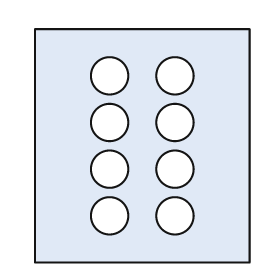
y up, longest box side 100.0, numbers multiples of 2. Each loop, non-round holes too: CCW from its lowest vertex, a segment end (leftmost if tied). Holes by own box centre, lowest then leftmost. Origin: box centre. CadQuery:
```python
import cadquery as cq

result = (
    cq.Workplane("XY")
    .moveTo(-46.0, -50.0)
    .lineTo(46.0, -50.0)
    .lineTo(46.0, 50.0)
    .lineTo(-46.0, 50.0)
    .close()
    .moveTo(-14.0, -30.0)
    .circle(8.0)
    .moveTo(14.0, -30.0)
    .circle(8.0)
    .moveTo(-14.0, -10.0)
    .circle(8.0)
    .moveTo(14.0, -10.0)
    .circle(8.0)
    .moveTo(-14.0, 10.0)
    .circle(8.0)
    .moveTo(14.0, 10.0)
    .circle(8.0)
    .moveTo(-14.0, 30.0)
    .circle(8.0)
    .moveTo(14.0, 30.0)
    .circle(8.0)
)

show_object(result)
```